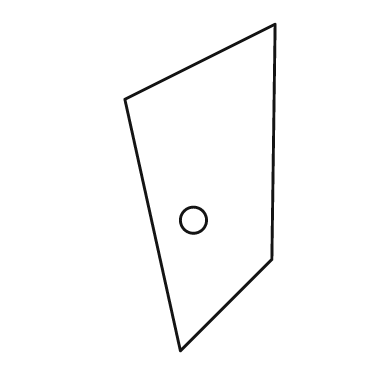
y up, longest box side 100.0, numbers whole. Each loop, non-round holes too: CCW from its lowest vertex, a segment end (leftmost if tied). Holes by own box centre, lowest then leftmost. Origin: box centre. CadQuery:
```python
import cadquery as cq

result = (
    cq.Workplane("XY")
    .moveTo(-6.0, -50.0)
    .lineTo(22.0, -22.0)
    .lineTo(23.0, 50.0)
    .lineTo(-23.0, 27.0)
    .close()
    .moveTo(-2.0, -10.0)
    .circle(4.0)
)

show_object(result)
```